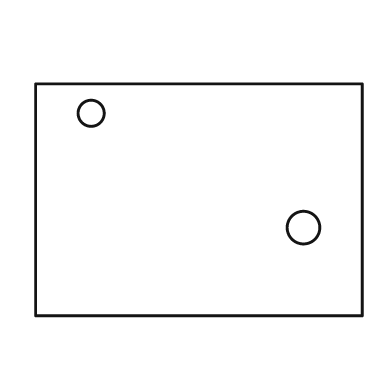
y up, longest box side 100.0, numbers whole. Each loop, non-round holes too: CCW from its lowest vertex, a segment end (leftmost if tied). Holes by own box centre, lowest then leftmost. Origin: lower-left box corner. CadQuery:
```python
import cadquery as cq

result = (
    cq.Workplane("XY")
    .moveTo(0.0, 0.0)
    .lineTo(100.0, 0.0)
    .lineTo(100.0, 71.0)
    .lineTo(0.0, 71.0)
    .close()
    .moveTo(82.0, 27.0)
    .circle(5.0)
    .moveTo(17.0, 62.0)
    .circle(4.0)
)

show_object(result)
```